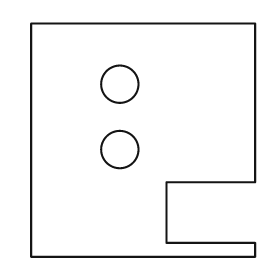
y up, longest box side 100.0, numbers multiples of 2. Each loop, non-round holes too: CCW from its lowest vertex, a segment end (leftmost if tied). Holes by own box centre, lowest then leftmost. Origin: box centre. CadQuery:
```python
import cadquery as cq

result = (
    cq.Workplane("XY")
    .moveTo(-48.0, -50.0)
    .lineTo(48.0, -50.0)
    .lineTo(48.0, -44.0)
    .lineTo(10.0, -44.0)
    .lineTo(10.0, -18.0)
    .lineTo(48.0, -18.0)
    .lineTo(48.0, 50.0)
    .lineTo(-48.0, 50.0)
    .close()
    .moveTo(-10.0, -4.0)
    .circle(8.0)
    .moveTo(-10.0, 24.0)
    .circle(8.0)
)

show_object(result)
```